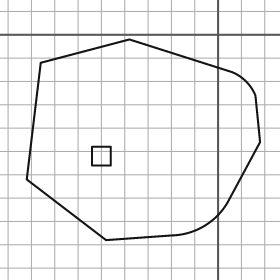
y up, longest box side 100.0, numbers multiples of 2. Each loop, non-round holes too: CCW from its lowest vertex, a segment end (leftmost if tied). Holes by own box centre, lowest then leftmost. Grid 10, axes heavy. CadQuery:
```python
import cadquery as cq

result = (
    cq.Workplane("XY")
    .moveTo(-48.0, -88.0)
    .lineTo(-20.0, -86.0)
    .threePointArc((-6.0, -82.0), (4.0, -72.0))
    .lineTo(18.0, -46.0)
    .lineTo(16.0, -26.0)
    .threePointArc((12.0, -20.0), (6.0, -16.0))
    .lineTo(-38.0, -2.0)
    .lineTo(-76.0, -12.0)
    .lineTo(-82.0, -62.0)
    .close()
    .moveTo(-54.0, -56.0)
    .lineTo(-46.0, -56.0)
    .lineTo(-46.0, -48.0)
    .lineTo(-54.0, -48.0)
    .close()
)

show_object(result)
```